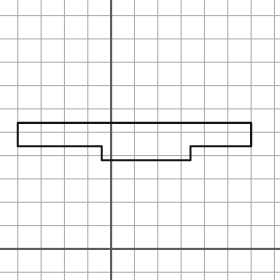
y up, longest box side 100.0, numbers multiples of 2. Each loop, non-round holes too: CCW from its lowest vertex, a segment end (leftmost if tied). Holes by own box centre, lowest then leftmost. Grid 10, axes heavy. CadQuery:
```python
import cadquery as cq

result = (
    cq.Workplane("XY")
    .moveTo(-4.0, 38.0)
    .lineTo(34.0, 38.0)
    .lineTo(34.0, 44.0)
    .lineTo(60.0, 44.0)
    .lineTo(60.0, 54.0)
    .lineTo(-40.0, 54.0)
    .lineTo(-40.0, 44.0)
    .lineTo(-4.0, 44.0)
    .close()
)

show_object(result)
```